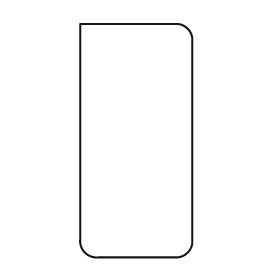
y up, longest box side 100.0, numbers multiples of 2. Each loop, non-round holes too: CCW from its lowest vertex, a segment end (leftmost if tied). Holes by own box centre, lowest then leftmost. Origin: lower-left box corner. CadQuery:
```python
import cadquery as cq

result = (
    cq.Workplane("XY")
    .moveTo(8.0, 0.0)
    .lineTo(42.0, 0.0)
    .threePointArc((46.0, 2.0), (48.0, 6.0))
    .lineTo(48.0, 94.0)
    .threePointArc((46.0, 98.0), (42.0, 100.0))
    .lineTo(0.0, 100.0)
    .lineTo(0.0, 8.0)
    .threePointArc((2.0, 2.0), (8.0, 0.0))
    .close()
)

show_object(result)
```